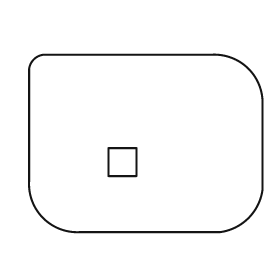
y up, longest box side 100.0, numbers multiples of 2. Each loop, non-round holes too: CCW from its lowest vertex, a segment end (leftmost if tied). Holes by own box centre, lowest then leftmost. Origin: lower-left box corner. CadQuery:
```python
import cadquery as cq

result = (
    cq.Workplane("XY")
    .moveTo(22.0, 0.0)
    .lineTo(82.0, 0.0)
    .threePointArc((94.0, 6.0), (100.0, 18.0))
    .lineTo(100.0, 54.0)
    .threePointArc((94.0, 70.0), (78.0, 76.0))
    .lineTo(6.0, 76.0)
    .threePointArc((2.0, 74.0), (0.0, 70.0))
    .lineTo(0.0, 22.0)
    .threePointArc((6.0, 6.0), (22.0, 0.0))
    .close()
    .moveTo(34.0, 24.0)
    .lineTo(46.0, 24.0)
    .lineTo(46.0, 36.0)
    .lineTo(34.0, 36.0)
    .close()
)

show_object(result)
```